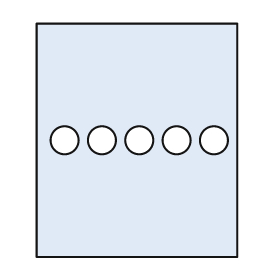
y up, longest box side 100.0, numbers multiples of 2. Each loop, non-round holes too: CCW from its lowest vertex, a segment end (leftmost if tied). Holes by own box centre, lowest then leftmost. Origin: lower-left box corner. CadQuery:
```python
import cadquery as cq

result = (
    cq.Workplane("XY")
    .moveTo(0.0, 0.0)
    .lineTo(86.0, 0.0)
    .lineTo(86.0, 100.0)
    .lineTo(0.0, 100.0)
    .close()
    .moveTo(12.0, 50.0)
    .circle(6.0)
    .moveTo(28.0, 50.0)
    .circle(6.0)
    .moveTo(44.0, 50.0)
    .circle(6.0)
    .moveTo(60.0, 50.0)
    .circle(6.0)
    .moveTo(76.0, 50.0)
    .circle(6.0)
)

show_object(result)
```